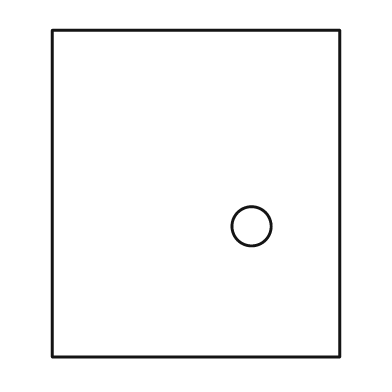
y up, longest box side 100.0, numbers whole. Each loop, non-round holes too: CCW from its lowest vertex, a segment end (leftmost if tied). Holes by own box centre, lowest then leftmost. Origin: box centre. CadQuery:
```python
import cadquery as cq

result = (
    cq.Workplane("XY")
    .moveTo(-44.0, -50.0)
    .lineTo(44.0, -50.0)
    .lineTo(44.0, 50.0)
    .lineTo(-44.0, 50.0)
    .close()
    .moveTo(17.0, -10.0)
    .circle(6.0)
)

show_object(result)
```